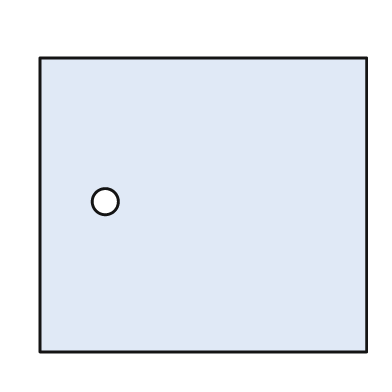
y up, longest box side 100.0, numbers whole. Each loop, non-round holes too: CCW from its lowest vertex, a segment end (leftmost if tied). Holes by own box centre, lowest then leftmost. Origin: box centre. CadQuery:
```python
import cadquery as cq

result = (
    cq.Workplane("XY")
    .moveTo(-50.0, -45.0)
    .lineTo(50.0, -45.0)
    .lineTo(50.0, 45.0)
    .lineTo(-50.0, 45.0)
    .close()
    .moveTo(-30.0, 1.0)
    .circle(4.0)
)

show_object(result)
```